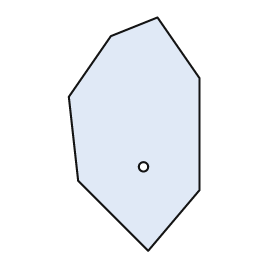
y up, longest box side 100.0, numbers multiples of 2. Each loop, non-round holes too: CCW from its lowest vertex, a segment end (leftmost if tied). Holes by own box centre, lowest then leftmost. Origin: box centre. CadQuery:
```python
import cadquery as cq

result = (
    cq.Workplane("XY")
    .moveTo(6.0, -50.0)
    .lineTo(28.0, -24.0)
    .lineTo(28.0, 24.0)
    .lineTo(10.0, 50.0)
    .lineTo(-10.0, 42.0)
    .lineTo(-28.0, 16.0)
    .lineTo(-24.0, -20.0)
    .close()
    .moveTo(4.0, -14.0)
    .circle(2.0)
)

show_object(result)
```